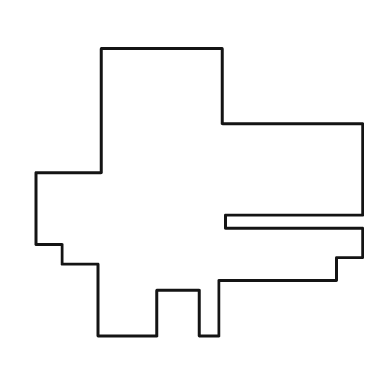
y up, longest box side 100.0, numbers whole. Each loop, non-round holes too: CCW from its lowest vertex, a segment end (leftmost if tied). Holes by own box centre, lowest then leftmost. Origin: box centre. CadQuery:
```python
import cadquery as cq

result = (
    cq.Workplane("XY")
    .moveTo(-31.0, -44.0)
    .lineTo(-13.0, -44.0)
    .lineTo(-13.0, -30.0)
    .lineTo(0.0, -30.0)
    .lineTo(0.0, -44.0)
    .lineTo(6.0, -44.0)
    .lineTo(6.0, -27.0)
    .lineTo(42.0, -27.0)
    .lineTo(42.0, -20.0)
    .lineTo(50.0, -20.0)
    .lineTo(50.0, -11.0)
    .lineTo(8.0, -11.0)
    .lineTo(8.0, -7.0)
    .lineTo(50.0, -7.0)
    .lineTo(50.0, 21.0)
    .lineTo(7.0, 21.0)
    .lineTo(7.0, 44.0)
    .lineTo(-30.0, 44.0)
    .lineTo(-30.0, 6.0)
    .lineTo(-50.0, 6.0)
    .lineTo(-50.0, -16.0)
    .lineTo(-42.0, -16.0)
    .lineTo(-42.0, -22.0)
    .lineTo(-31.0, -22.0)
    .close()
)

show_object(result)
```